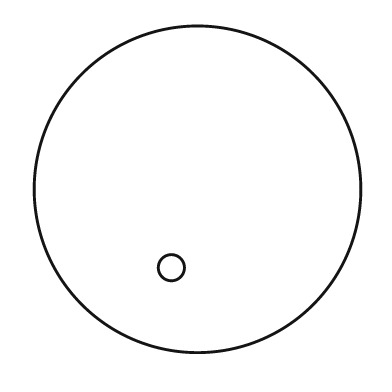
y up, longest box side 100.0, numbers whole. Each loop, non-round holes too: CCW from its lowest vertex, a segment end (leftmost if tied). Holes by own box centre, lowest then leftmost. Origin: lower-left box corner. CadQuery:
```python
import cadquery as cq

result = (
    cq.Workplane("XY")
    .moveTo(50.0, 50.0)
    .circle(50.0)
    .moveTo(42.0, 26.0)
    .circle(4.0)
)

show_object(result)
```